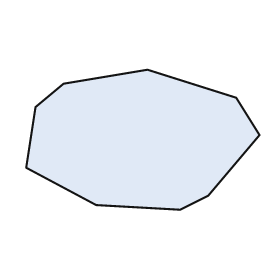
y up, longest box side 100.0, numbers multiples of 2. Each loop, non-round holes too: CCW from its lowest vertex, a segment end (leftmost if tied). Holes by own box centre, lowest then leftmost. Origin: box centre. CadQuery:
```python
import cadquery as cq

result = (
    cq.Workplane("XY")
    .moveTo(16.0, -30.0)
    .lineTo(28.0, -24.0)
    .lineTo(50.0, 2.0)
    .lineTo(40.0, 18.0)
    .lineTo(2.0, 30.0)
    .lineTo(-34.0, 24.0)
    .lineTo(-46.0, 14.0)
    .lineTo(-50.0, -12.0)
    .lineTo(-20.0, -28.0)
    .close()
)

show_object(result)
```